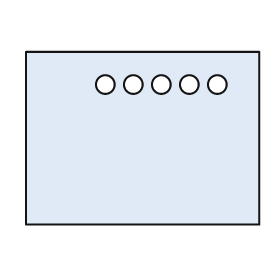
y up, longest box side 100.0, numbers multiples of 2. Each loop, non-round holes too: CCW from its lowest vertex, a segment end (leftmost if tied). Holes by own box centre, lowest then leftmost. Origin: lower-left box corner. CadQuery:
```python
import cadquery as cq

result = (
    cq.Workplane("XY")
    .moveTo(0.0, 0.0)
    .lineTo(100.0, 0.0)
    .lineTo(100.0, 74.0)
    .lineTo(0.0, 74.0)
    .close()
    .moveTo(34.0, 60.0)
    .circle(4.0)
    .moveTo(46.0, 60.0)
    .circle(4.0)
    .moveTo(58.0, 60.0)
    .circle(4.0)
    .moveTo(70.0, 60.0)
    .circle(4.0)
    .moveTo(82.0, 60.0)
    .circle(4.0)
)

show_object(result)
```